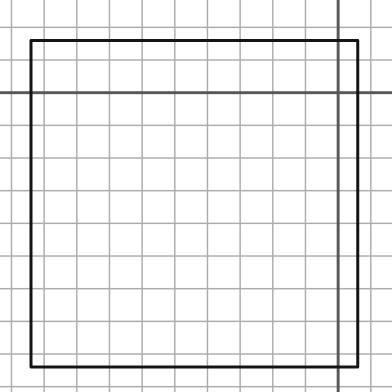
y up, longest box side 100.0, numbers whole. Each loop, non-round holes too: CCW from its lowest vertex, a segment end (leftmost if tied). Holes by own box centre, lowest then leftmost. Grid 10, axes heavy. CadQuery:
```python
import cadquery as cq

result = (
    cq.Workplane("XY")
    .moveTo(-94.0, -84.0)
    .lineTo(6.0, -84.0)
    .lineTo(6.0, 16.0)
    .lineTo(-94.0, 16.0)
    .close()
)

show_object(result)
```